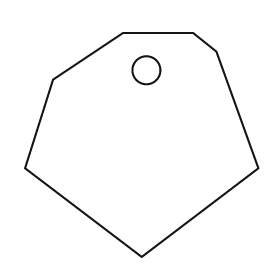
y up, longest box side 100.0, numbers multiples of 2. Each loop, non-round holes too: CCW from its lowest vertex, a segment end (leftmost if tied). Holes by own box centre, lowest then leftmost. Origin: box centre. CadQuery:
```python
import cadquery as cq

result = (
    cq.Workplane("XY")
    .moveTo(0.0, -48.0)
    .lineTo(50.0, -10.0)
    .lineTo(32.0, 40.0)
    .lineTo(22.0, 48.0)
    .lineTo(-8.0, 48.0)
    .lineTo(-38.0, 28.0)
    .lineTo(-50.0, -10.0)
    .close()
    .moveTo(2.0, 32.0)
    .circle(6.0)
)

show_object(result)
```